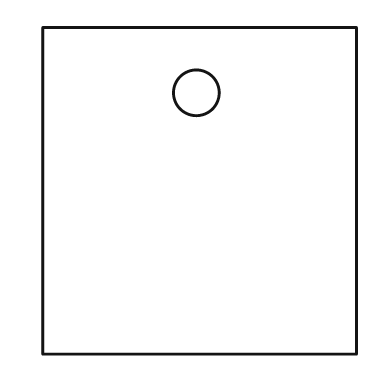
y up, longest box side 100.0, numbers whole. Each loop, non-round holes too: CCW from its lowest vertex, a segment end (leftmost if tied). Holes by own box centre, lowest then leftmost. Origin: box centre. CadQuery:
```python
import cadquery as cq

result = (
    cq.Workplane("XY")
    .moveTo(-48.0, -50.0)
    .lineTo(48.0, -50.0)
    .lineTo(48.0, 50.0)
    .lineTo(-48.0, 50.0)
    .close()
    .moveTo(-1.0, 30.0)
    .circle(7.0)
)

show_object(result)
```